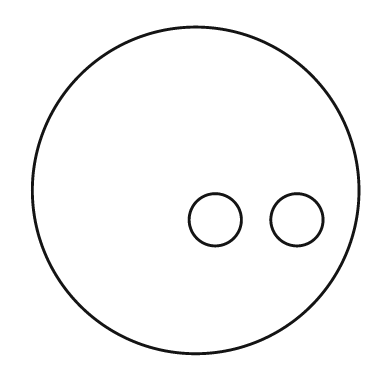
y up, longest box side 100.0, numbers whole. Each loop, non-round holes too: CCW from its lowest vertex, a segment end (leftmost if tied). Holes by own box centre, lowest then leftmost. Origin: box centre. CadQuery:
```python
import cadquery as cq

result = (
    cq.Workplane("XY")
    .moveTo(0.0, 0.0)
    .circle(50.0)
    .moveTo(6.0, -9.0)
    .circle(8.0)
    .moveTo(31.0, -9.0)
    .circle(8.0)
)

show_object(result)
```